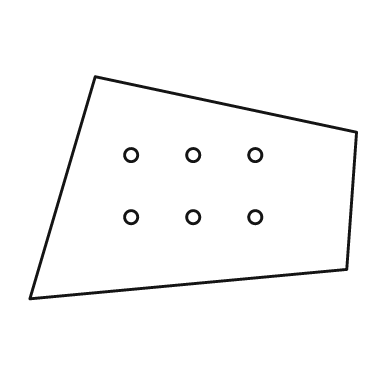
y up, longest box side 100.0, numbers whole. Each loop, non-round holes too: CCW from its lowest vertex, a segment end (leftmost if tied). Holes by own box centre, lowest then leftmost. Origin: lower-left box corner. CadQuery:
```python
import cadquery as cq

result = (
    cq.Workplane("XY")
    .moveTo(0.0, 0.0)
    .lineTo(97.0, 9.0)
    .lineTo(100.0, 51.0)
    .lineTo(20.0, 68.0)
    .close()
    .moveTo(31.0, 25.0)
    .circle(2.0)
    .moveTo(50.0, 25.0)
    .circle(2.0)
    .moveTo(69.0, 25.0)
    .circle(2.0)
    .moveTo(31.0, 44.0)
    .circle(2.0)
    .moveTo(50.0, 44.0)
    .circle(2.0)
    .moveTo(69.0, 44.0)
    .circle(2.0)
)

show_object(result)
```